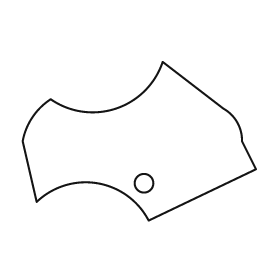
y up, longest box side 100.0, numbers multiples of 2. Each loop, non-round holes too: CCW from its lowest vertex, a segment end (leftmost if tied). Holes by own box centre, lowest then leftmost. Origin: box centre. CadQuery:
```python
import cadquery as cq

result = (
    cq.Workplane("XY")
    .moveTo(4.0, -34.0)
    .lineTo(50.0, -12.0)
    .lineTo(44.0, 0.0)
    .threePointArc((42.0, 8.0), (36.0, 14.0))
    .lineTo(10.0, 34.0)
    .threePointArc((-10.0, 14.0), (-38.0, 18.0))
    .threePointArc((-46.0, 10.0), (-50.0, 0.0))
    .lineTo(-44.0, -26.0)
    .threePointArc((-18.0, -18.0), (4.0, -34.0))
    .close()
    .moveTo(2.0, -18.0)
    .circle(4.0)
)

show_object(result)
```